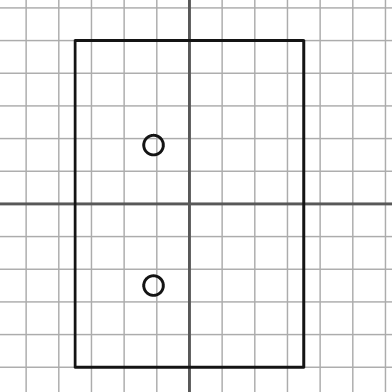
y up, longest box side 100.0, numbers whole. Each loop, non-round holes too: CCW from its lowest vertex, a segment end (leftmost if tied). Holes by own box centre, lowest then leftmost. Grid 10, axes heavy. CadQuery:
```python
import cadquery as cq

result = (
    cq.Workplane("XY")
    .moveTo(-35.0, -50.0)
    .lineTo(35.0, -50.0)
    .lineTo(35.0, 50.0)
    .lineTo(-35.0, 50.0)
    .close()
    .moveTo(-11.0, -25.0)
    .circle(3.0)
    .moveTo(-11.0, 18.0)
    .circle(3.0)
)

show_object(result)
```